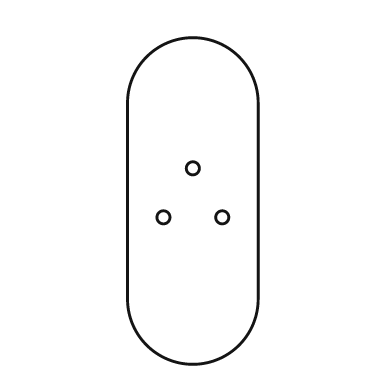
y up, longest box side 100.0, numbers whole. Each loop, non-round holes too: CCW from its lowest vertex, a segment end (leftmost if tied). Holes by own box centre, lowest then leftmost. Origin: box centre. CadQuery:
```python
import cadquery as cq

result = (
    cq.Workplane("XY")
    .moveTo(-20.0, -30.0)
    .threePointArc((0.0, -50.0), (20.0, -30.0))
    .lineTo(20.0, 30.0)
    .threePointArc((0.0, 50.0), (-20.0, 30.0))
    .close()
    .moveTo(-9.0, -5.0)
    .circle(2.0)
    .moveTo(9.0, -5.0)
    .circle(2.0)
    .moveTo(0.0, 10.0)
    .circle(2.0)
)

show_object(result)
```